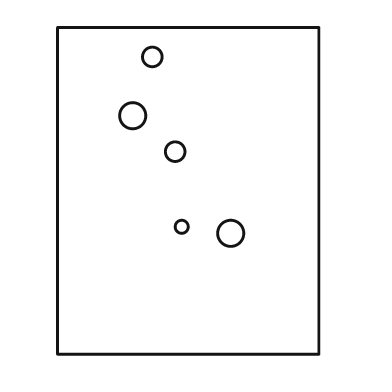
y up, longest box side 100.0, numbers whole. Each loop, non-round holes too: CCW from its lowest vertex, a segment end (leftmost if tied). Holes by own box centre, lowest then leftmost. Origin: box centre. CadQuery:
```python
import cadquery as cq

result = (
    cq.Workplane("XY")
    .moveTo(-40.0, -50.0)
    .lineTo(40.0, -50.0)
    .lineTo(40.0, 50.0)
    .lineTo(-40.0, 50.0)
    .close()
    .moveTo(13.0, -13.0)
    .circle(4.0)
    .moveTo(-2.0, -11.0)
    .circle(2.0)
    .moveTo(-4.0, 12.0)
    .circle(3.0)
    .moveTo(-17.0, 23.0)
    .circle(4.0)
    .moveTo(-11.0, 41.0)
    .circle(3.0)
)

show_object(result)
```